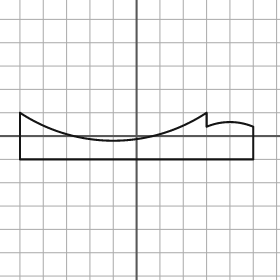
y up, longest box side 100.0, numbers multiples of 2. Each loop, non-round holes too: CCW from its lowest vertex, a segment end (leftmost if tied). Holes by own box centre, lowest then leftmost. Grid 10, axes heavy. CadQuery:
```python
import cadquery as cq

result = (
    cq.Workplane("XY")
    .moveTo(-50.0, -10.0)
    .lineTo(50.0, -10.0)
    .lineTo(50.0, 4.0)
    .threePointArc((40.0, 6.0), (30.0, 4.0))
    .lineTo(30.0, 10.0)
    .threePointArc((-10.0, -2.0), (-50.0, 10.0))
    .close()
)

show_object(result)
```